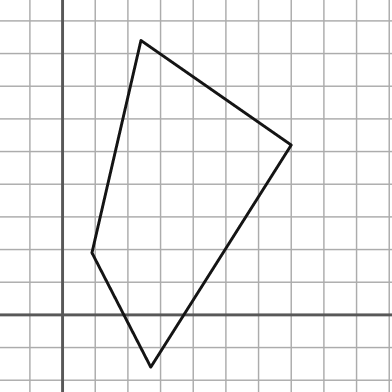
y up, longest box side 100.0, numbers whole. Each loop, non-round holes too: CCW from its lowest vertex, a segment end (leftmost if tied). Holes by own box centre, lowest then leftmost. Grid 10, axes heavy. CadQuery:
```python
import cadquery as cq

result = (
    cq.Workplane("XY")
    .moveTo(27.0, -16.0)
    .lineTo(70.0, 52.0)
    .lineTo(24.0, 84.0)
    .lineTo(9.0, 19.0)
    .close()
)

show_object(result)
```